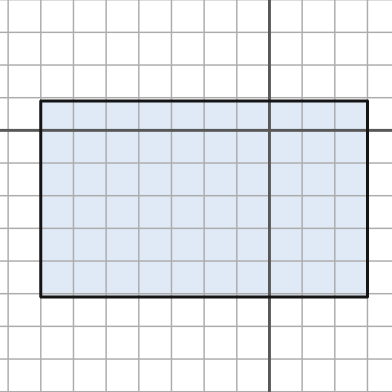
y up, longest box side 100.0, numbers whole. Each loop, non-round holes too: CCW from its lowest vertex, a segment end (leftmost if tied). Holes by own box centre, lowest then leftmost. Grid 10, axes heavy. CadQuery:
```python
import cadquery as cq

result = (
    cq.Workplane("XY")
    .moveTo(-70.0, -51.0)
    .lineTo(30.0, -51.0)
    .lineTo(30.0, 9.0)
    .lineTo(-70.0, 9.0)
    .close()
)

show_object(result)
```